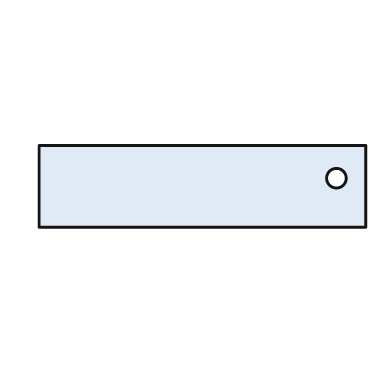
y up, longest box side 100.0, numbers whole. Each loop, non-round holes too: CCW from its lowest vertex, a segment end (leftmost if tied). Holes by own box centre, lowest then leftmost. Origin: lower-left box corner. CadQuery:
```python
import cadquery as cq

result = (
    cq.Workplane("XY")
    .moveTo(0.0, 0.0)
    .lineTo(100.0, 0.0)
    .lineTo(100.0, 25.0)
    .lineTo(0.0, 25.0)
    .close()
    .moveTo(91.0, 15.0)
    .circle(3.0)
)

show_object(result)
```